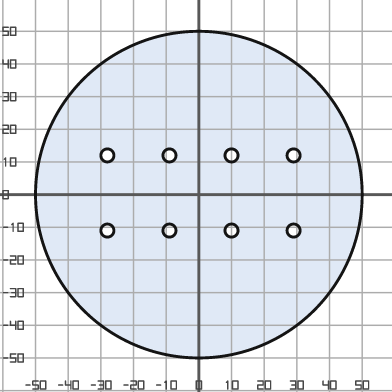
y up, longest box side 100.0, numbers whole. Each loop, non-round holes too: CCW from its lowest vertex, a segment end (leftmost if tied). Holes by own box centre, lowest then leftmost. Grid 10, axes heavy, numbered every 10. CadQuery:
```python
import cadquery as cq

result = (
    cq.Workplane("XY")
    .moveTo(0.0, 0.0)
    .circle(50.0)
    .moveTo(-28.0, -11.0)
    .circle(2.0)
    .moveTo(-9.0, -11.0)
    .circle(2.0)
    .moveTo(10.0, -11.0)
    .circle(2.0)
    .moveTo(29.0, -11.0)
    .circle(2.0)
    .moveTo(-28.0, 12.0)
    .circle(2.0)
    .moveTo(-9.0, 12.0)
    .circle(2.0)
    .moveTo(10.0, 12.0)
    .circle(2.0)
    .moveTo(29.0, 12.0)
    .circle(2.0)
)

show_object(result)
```